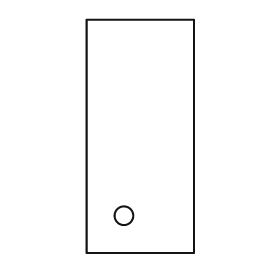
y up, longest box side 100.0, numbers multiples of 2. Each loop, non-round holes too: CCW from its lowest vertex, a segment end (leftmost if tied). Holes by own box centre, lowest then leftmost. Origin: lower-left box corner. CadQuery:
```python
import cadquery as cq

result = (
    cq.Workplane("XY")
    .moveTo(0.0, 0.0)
    .lineTo(46.0, 0.0)
    .lineTo(46.0, 100.0)
    .lineTo(0.0, 100.0)
    .close()
    .moveTo(16.0, 16.0)
    .circle(4.0)
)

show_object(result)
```